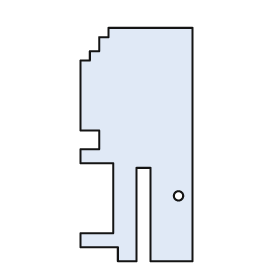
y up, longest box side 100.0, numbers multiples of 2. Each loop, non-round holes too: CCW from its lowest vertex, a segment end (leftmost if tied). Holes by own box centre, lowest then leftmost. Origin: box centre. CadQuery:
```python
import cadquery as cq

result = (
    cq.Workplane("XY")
    .moveTo(-8.0, -50.0)
    .lineTo(0.0, -50.0)
    .lineTo(0.0, -10.0)
    .lineTo(6.0, -10.0)
    .lineTo(6.0, -50.0)
    .lineTo(24.0, -50.0)
    .lineTo(24.0, 50.0)
    .lineTo(-12.0, 50.0)
    .lineTo(-12.0, 46.0)
    .lineTo(-16.0, 46.0)
    .lineTo(-16.0, 40.0)
    .lineTo(-20.0, 40.0)
    .lineTo(-20.0, 36.0)
    .lineTo(-24.0, 36.0)
    .lineTo(-24.0, 6.0)
    .lineTo(-16.0, 6.0)
    .lineTo(-16.0, -2.0)
    .lineTo(-24.0, -2.0)
    .lineTo(-24.0, -8.0)
    .lineTo(-10.0, -8.0)
    .lineTo(-10.0, -38.0)
    .lineTo(-24.0, -38.0)
    .lineTo(-24.0, -44.0)
    .lineTo(-8.0, -44.0)
    .close()
    .moveTo(18.0, -22.0)
    .circle(2.0)
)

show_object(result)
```